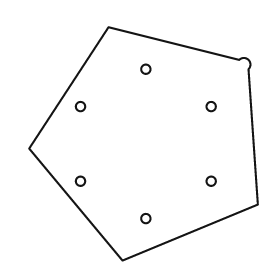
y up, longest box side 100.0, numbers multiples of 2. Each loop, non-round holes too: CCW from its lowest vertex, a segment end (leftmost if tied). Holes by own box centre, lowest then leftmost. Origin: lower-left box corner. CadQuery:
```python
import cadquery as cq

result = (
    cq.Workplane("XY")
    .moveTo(40.0, 0.0)
    .lineTo(98.0, 24.0)
    .lineTo(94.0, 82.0)
    .threePointArc((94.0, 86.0), (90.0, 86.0))
    .lineTo(34.0, 100.0)
    .lineTo(0.0, 48.0)
    .close()
    .moveTo(50.0, 18.0)
    .circle(2.0)
    .moveTo(22.0, 34.0)
    .circle(2.0)
    .moveTo(78.0, 34.0)
    .circle(2.0)
    .moveTo(22.0, 66.0)
    .circle(2.0)
    .moveTo(78.0, 66.0)
    .circle(2.0)
    .moveTo(50.0, 82.0)
    .circle(2.0)
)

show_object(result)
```